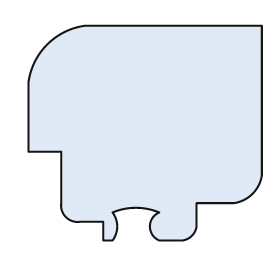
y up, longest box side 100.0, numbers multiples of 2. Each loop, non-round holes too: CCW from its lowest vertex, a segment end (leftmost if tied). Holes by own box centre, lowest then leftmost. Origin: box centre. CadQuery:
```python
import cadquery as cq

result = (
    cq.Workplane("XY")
    .moveTo(-18.0, -46.0)
    .lineTo(-14.0, -46.0)
    .threePointArc((-12.0, -40.0), (-14.0, -34.0))
    .threePointArc((-4.0, -32.0), (6.0, -34.0))
    .threePointArc((2.0, -40.0), (6.0, -46.0))
    .lineTo(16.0, -46.0)
    .threePointArc((20.0, -44.0), (22.0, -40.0))
    .lineTo(22.0, -30.0)
    .lineTo(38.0, -30.0)
    .threePointArc((46.0, -26.0), (50.0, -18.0))
    .lineTo(50.0, 46.0)
    .lineTo(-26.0, 46.0)
    .threePointArc((-42.0, 38.0), (-50.0, 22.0))
    .lineTo(-50.0, -8.0)
    .lineTo(-36.0, -8.0)
    .lineTo(-36.0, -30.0)
    .threePointArc((-34.0, -36.0), (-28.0, -38.0))
    .lineTo(-18.0, -38.0)
    .close()
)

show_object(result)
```